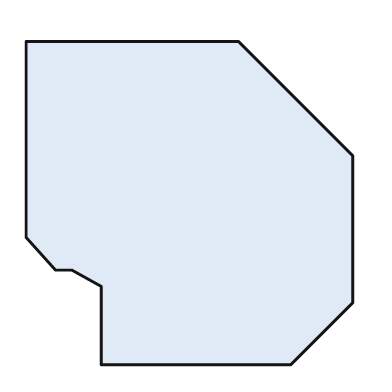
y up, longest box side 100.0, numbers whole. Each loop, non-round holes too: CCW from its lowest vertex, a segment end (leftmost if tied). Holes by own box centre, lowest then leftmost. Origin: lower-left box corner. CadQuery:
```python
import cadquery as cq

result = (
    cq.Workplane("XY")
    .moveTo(23.0, 0.0)
    .lineTo(81.0, 0.0)
    .lineTo(100.0, 19.0)
    .lineTo(100.0, 64.0)
    .lineTo(65.0, 99.0)
    .lineTo(0.0, 99.0)
    .lineTo(0.0, 39.0)
    .lineTo(9.0, 29.0)
    .lineTo(14.0, 29.0)
    .lineTo(23.0, 24.0)
    .close()
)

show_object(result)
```